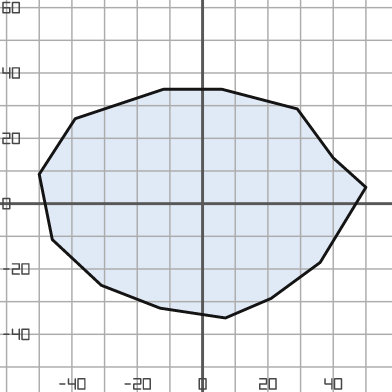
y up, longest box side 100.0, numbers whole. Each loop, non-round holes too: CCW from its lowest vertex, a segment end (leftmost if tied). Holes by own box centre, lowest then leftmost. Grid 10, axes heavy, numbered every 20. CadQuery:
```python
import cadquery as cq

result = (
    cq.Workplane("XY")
    .moveTo(7.0, -35.0)
    .lineTo(21.0, -29.0)
    .lineTo(36.0, -18.0)
    .lineTo(50.0, 5.0)
    .lineTo(40.0, 14.0)
    .lineTo(29.0, 29.0)
    .lineTo(6.0, 35.0)
    .lineTo(-12.0, 35.0)
    .lineTo(-39.0, 26.0)
    .lineTo(-50.0, 9.0)
    .lineTo(-46.0, -11.0)
    .lineTo(-31.0, -25.0)
    .lineTo(-13.0, -32.0)
    .close()
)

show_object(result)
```